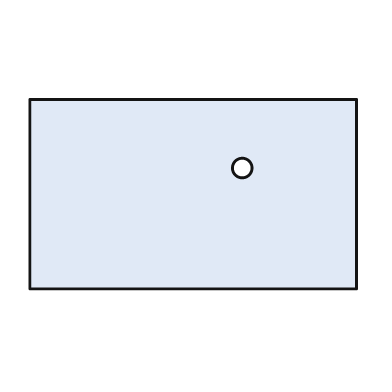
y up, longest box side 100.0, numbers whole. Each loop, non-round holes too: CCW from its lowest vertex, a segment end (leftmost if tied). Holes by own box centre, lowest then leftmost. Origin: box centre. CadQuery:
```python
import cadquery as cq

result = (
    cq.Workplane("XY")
    .moveTo(-50.0, -29.0)
    .lineTo(50.0, -29.0)
    .lineTo(50.0, 29.0)
    .lineTo(-50.0, 29.0)
    .close()
    .moveTo(15.0, 8.0)
    .circle(3.0)
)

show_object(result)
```